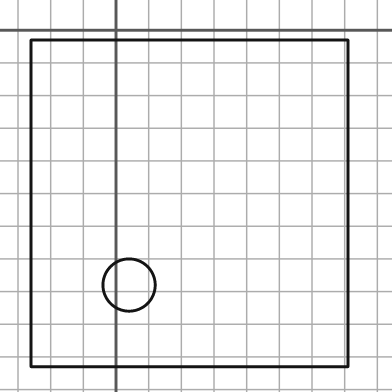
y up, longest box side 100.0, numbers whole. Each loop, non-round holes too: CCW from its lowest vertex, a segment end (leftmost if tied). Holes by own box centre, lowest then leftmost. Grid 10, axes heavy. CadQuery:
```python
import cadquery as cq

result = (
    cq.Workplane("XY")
    .moveTo(-26.0, -103.0)
    .lineTo(71.0, -103.0)
    .lineTo(71.0, -3.0)
    .lineTo(-26.0, -3.0)
    .close()
    .moveTo(4.0, -78.0)
    .circle(8.0)
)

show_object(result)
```